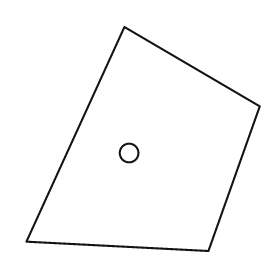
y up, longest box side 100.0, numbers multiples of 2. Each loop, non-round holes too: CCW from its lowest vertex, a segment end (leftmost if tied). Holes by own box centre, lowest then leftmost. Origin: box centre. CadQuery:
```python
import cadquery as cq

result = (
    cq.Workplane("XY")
    .moveTo(28.0, -48.0)
    .lineTo(50.0, 14.0)
    .lineTo(-8.0, 48.0)
    .lineTo(-50.0, -44.0)
    .close()
    .moveTo(-6.0, -6.0)
    .circle(4.0)
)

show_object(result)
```